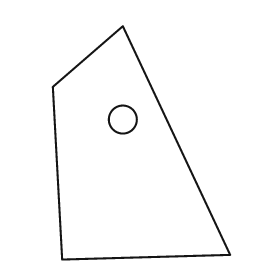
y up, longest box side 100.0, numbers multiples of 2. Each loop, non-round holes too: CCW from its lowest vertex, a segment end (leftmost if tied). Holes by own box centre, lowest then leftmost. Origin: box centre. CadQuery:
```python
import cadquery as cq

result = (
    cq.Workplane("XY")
    .moveTo(-34.0, -50.0)
    .lineTo(38.0, -48.0)
    .lineTo(-8.0, 50.0)
    .lineTo(-38.0, 24.0)
    .close()
    .moveTo(-8.0, 10.0)
    .circle(6.0)
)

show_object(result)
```